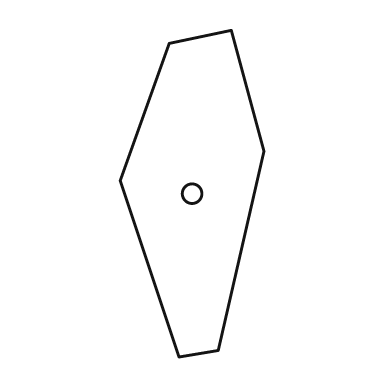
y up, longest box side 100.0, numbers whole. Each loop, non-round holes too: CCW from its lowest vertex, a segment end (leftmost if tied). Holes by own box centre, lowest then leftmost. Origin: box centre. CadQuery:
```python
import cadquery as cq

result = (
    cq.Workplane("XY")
    .moveTo(-4.0, -50.0)
    .lineTo(8.0, -48.0)
    .lineTo(22.0, 13.0)
    .lineTo(12.0, 50.0)
    .lineTo(-7.0, 46.0)
    .lineTo(-22.0, 4.0)
    .close()
    .moveTo(0.0, 0.0)
    .circle(3.0)
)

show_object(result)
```